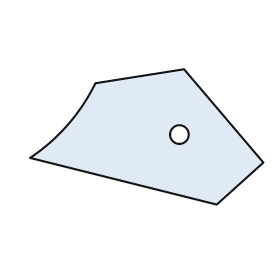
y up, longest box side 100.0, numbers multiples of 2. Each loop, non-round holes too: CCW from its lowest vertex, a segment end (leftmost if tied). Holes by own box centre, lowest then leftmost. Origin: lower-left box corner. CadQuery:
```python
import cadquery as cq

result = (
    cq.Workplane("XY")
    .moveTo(80.0, 0.0)
    .lineTo(100.0, 18.0)
    .lineTo(66.0, 58.0)
    .lineTo(28.0, 52.0)
    .threePointArc((16.0, 34.0), (0.0, 20.0))
    .close()
    .moveTo(64.0, 30.0)
    .circle(4.0)
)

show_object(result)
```